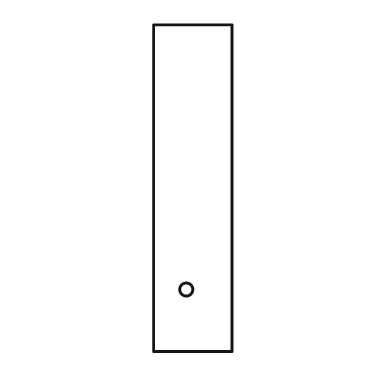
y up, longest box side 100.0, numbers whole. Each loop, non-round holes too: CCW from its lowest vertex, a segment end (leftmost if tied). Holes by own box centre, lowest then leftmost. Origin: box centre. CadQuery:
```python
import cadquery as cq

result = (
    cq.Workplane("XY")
    .moveTo(-12.0, -50.0)
    .lineTo(12.0, -50.0)
    .lineTo(12.0, 50.0)
    .lineTo(-12.0, 50.0)
    .close()
    .moveTo(-2.0, -31.0)
    .circle(2.0)
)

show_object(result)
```